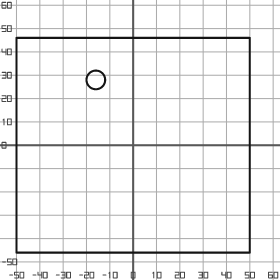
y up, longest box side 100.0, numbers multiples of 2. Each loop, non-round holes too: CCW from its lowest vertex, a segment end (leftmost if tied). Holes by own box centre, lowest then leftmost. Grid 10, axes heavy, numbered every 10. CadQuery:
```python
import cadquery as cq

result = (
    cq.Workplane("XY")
    .moveTo(-50.0, -46.0)
    .lineTo(50.0, -46.0)
    .lineTo(50.0, 46.0)
    .lineTo(-50.0, 46.0)
    .close()
    .moveTo(-16.0, 28.0)
    .circle(4.0)
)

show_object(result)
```